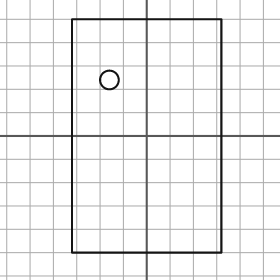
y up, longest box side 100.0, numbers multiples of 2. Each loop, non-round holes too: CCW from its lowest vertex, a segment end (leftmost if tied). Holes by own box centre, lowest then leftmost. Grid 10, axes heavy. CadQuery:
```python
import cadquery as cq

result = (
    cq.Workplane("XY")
    .moveTo(-32.0, -50.0)
    .lineTo(32.0, -50.0)
    .lineTo(32.0, 50.0)
    .lineTo(-32.0, 50.0)
    .close()
    .moveTo(-16.0, 24.0)
    .circle(4.0)
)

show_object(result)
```